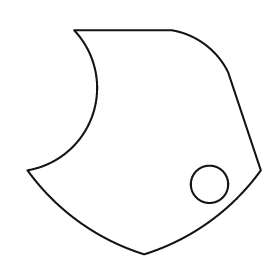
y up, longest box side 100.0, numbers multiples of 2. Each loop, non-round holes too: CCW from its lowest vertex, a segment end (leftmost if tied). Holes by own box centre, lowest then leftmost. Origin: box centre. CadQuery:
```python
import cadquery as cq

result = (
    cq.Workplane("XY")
    .moveTo(0.0, -48.0)
    .threePointArc((28.0, -34.0), (50.0, -12.0))
    .lineTo(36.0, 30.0)
    .threePointArc((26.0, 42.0), (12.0, 48.0))
    .lineTo(-30.0, 48.0)
    .threePointArc((-22.0, 12.0), (-50.0, -12.0))
    .threePointArc((-28.0, -34.0), (0.0, -48.0))
    .close()
    .moveTo(28.0, -18.0)
    .circle(8.0)
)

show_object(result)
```